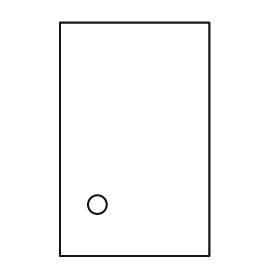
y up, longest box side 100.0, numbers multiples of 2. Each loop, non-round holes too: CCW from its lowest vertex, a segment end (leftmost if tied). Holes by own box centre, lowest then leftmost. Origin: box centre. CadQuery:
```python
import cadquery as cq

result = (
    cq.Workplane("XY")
    .moveTo(-32.0, -50.0)
    .lineTo(32.0, -50.0)
    .lineTo(32.0, 50.0)
    .lineTo(-32.0, 50.0)
    .close()
    .moveTo(-16.0, -28.0)
    .circle(4.0)
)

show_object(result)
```